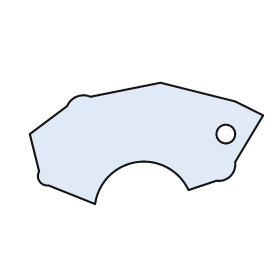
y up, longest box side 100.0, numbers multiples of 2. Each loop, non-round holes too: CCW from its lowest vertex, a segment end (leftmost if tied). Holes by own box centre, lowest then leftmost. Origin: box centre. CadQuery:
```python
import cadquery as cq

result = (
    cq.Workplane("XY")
    .moveTo(-22.0, -26.0)
    .threePointArc((-4.0, -8.0), (18.0, -20.0))
    .lineTo(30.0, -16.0)
    .threePointArc((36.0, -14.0), (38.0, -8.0))
    .lineTo(50.0, 12.0)
    .lineTo(38.0, 18.0)
    .lineTo(6.0, 26.0)
    .lineTo(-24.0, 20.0)
    .threePointArc((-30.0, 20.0), (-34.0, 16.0))
    .lineTo(-50.0, 4.0)
    .lineTo(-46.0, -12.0)
    .threePointArc((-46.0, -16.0), (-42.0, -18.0))
    .close()
    .moveTo(34.0, 4.0)
    .circle(4.0)
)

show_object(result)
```